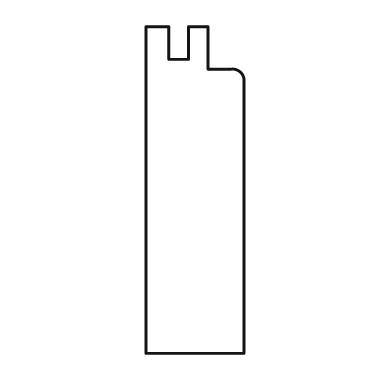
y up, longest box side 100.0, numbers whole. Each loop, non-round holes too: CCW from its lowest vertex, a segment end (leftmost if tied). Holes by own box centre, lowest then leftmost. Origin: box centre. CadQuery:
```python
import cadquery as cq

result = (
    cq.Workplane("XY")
    .moveTo(-15.0, -50.0)
    .lineTo(15.0, -50.0)
    .lineTo(15.0, 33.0)
    .threePointArc((14.0, 36.0), (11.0, 37.0))
    .lineTo(4.0, 37.0)
    .lineTo(4.0, 50.0)
    .lineTo(-2.0, 50.0)
    .lineTo(-2.0, 40.0)
    .lineTo(-8.0, 40.0)
    .lineTo(-8.0, 50.0)
    .lineTo(-15.0, 50.0)
    .close()
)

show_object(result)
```